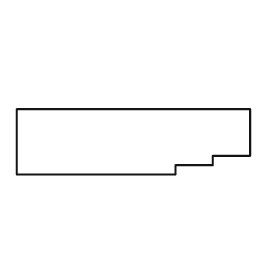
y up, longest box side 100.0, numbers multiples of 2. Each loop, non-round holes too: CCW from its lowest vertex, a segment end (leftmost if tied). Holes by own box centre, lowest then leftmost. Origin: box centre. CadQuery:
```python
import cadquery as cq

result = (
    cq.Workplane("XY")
    .moveTo(-50.0, -14.0)
    .lineTo(18.0, -14.0)
    .lineTo(18.0, -10.0)
    .lineTo(34.0, -10.0)
    .lineTo(34.0, -6.0)
    .lineTo(50.0, -6.0)
    .lineTo(50.0, 14.0)
    .lineTo(-50.0, 14.0)
    .close()
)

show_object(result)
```